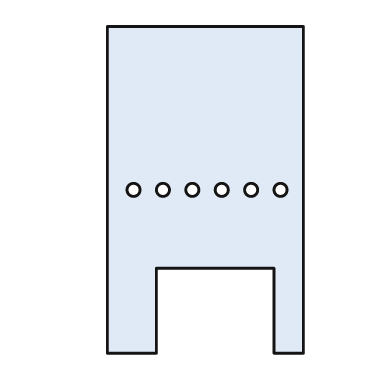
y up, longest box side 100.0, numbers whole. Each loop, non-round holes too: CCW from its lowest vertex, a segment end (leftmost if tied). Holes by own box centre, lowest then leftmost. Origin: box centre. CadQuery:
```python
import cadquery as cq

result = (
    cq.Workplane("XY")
    .moveTo(-30.0, -50.0)
    .lineTo(-15.0, -50.0)
    .lineTo(-15.0, -24.0)
    .lineTo(21.0, -24.0)
    .lineTo(21.0, -50.0)
    .lineTo(30.0, -50.0)
    .lineTo(30.0, 50.0)
    .lineTo(-30.0, 50.0)
    .close()
    .moveTo(-22.0, 0.0)
    .circle(2.0)
    .moveTo(-13.0, 0.0)
    .circle(2.0)
    .moveTo(-4.0, 0.0)
    .circle(2.0)
    .moveTo(5.0, 0.0)
    .circle(2.0)
    .moveTo(14.0, 0.0)
    .circle(2.0)
    .moveTo(23.0, 0.0)
    .circle(2.0)
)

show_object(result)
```